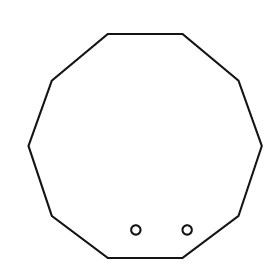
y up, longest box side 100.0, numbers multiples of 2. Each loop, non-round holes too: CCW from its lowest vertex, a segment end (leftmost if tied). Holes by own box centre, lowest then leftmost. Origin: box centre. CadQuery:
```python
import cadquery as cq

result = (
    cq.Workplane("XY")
    .moveTo(-16.0, -48.0)
    .lineTo(16.0, -48.0)
    .lineTo(40.0, -30.0)
    .lineTo(50.0, 0.0)
    .lineTo(40.0, 28.0)
    .lineTo(16.0, 48.0)
    .lineTo(-16.0, 48.0)
    .lineTo(-40.0, 28.0)
    .lineTo(-50.0, 0.0)
    .lineTo(-40.0, -30.0)
    .close()
    .moveTo(-4.0, -36.0)
    .circle(2.0)
    .moveTo(18.0, -36.0)
    .circle(2.0)
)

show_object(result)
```